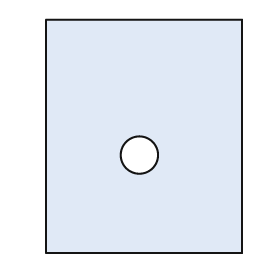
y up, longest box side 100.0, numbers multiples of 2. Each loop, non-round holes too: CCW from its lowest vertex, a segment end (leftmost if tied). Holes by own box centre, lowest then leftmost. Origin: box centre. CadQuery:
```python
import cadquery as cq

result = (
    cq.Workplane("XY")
    .moveTo(-42.0, -50.0)
    .lineTo(42.0, -50.0)
    .lineTo(42.0, 50.0)
    .lineTo(-42.0, 50.0)
    .close()
    .moveTo(-2.0, -8.0)
    .circle(8.0)
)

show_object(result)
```